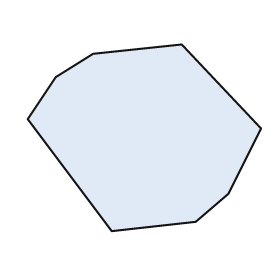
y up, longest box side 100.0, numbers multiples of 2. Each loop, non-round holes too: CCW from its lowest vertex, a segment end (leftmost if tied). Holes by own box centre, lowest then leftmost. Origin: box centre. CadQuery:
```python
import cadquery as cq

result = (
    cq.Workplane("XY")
    .moveTo(-14.0, -40.0)
    .lineTo(22.0, -36.0)
    .lineTo(36.0, -24.0)
    .lineTo(50.0, 4.0)
    .lineTo(16.0, 40.0)
    .lineTo(-22.0, 36.0)
    .lineTo(-38.0, 26.0)
    .lineTo(-50.0, 8.0)
    .close()
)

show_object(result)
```